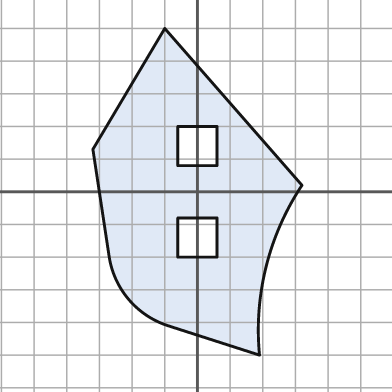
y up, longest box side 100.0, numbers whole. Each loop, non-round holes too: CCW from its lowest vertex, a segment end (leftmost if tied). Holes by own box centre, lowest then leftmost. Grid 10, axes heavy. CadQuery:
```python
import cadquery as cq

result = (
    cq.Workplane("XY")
    .moveTo(19.0, -50.0)
    .threePointArc((21.0, -23.0), (32.0, 2.0))
    .lineTo(-10.0, 50.0)
    .lineTo(-32.0, 13.0)
    .lineTo(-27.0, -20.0)
    .threePointArc((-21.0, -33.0), (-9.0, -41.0))
    .close()
    .moveTo(-6.0, -20.0)
    .lineTo(6.0, -20.0)
    .lineTo(6.0, -8.0)
    .lineTo(-6.0, -8.0)
    .close()
    .moveTo(-6.0, 8.0)
    .lineTo(6.0, 8.0)
    .lineTo(6.0, 20.0)
    .lineTo(-6.0, 20.0)
    .close()
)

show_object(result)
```